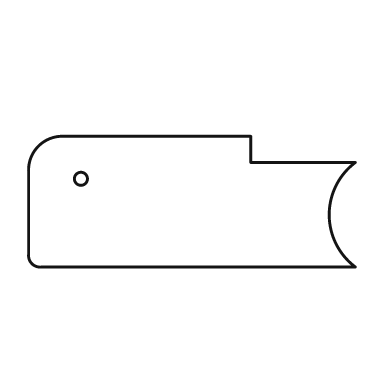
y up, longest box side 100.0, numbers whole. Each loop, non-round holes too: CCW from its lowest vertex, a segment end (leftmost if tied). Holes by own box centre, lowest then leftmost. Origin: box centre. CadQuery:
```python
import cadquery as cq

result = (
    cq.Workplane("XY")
    .moveTo(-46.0, -20.0)
    .lineTo(50.0, -20.0)
    .threePointArc((42.0, -4.0), (50.0, 12.0))
    .lineTo(18.0, 12.0)
    .lineTo(18.0, 20.0)
    .lineTo(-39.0, 20.0)
    .threePointArc((-47.0, 17.0), (-50.0, 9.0))
    .lineTo(-50.0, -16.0)
    .threePointArc((-49.0, -19.0), (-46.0, -20.0))
    .close()
    .moveTo(-34.0, 7.0)
    .circle(2.0)
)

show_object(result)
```